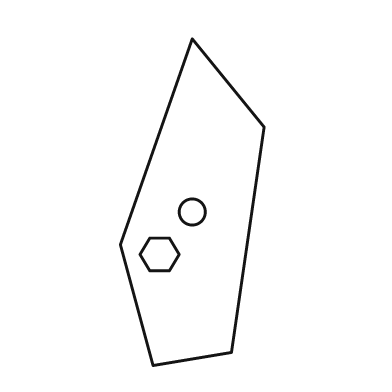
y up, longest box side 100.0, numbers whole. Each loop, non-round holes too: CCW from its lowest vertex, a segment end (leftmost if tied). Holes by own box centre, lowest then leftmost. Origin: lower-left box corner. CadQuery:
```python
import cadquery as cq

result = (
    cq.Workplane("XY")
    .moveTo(10.0, 0.0)
    .lineTo(34.0, 4.0)
    .lineTo(44.0, 73.0)
    .lineTo(22.0, 100.0)
    .lineTo(0.0, 37.0)
    .close()
    .moveTo(9.0, 29.0)
    .lineTo(15.0, 29.0)
    .lineTo(18.0, 34.0)
    .lineTo(15.0, 39.0)
    .lineTo(9.0, 39.0)
    .lineTo(6.0, 34.0)
    .close()
    .moveTo(22.0, 47.0)
    .circle(4.0)
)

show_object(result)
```